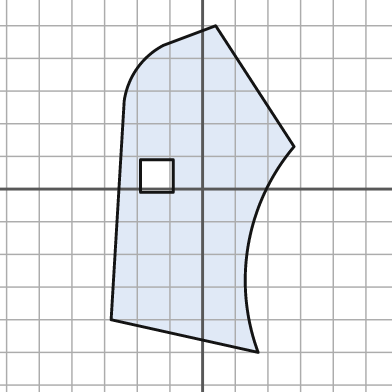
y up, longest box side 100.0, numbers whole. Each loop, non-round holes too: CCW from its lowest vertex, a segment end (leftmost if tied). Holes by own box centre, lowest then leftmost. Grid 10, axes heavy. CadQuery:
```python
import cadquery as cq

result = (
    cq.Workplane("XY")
    .moveTo(17.0, -50.0)
    .threePointArc((14.0, -17.0), (28.0, 13.0))
    .lineTo(4.0, 50.0)
    .lineTo(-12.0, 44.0)
    .threePointArc((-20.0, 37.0), (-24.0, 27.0))
    .lineTo(-28.0, -40.0)
    .close()
    .moveTo(-19.0, -1.0)
    .lineTo(-9.0, -1.0)
    .lineTo(-9.0, 9.0)
    .lineTo(-19.0, 9.0)
    .close()
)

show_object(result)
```